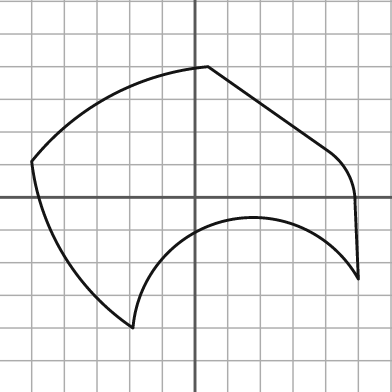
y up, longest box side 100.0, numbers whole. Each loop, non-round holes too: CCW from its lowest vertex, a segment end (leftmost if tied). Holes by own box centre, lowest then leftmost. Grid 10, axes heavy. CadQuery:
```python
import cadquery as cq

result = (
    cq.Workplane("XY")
    .moveTo(-19.0, -40.0)
    .threePointArc((10.0, -7.0), (50.0, -25.0))
    .lineTo(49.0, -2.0)
    .threePointArc((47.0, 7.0), (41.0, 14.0))
    .lineTo(4.0, 40.0)
    .threePointArc((-26.0, 31.0), (-50.0, 11.0))
    .threePointArc((-40.0, -18.0), (-19.0, -40.0))
    .close()
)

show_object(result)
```